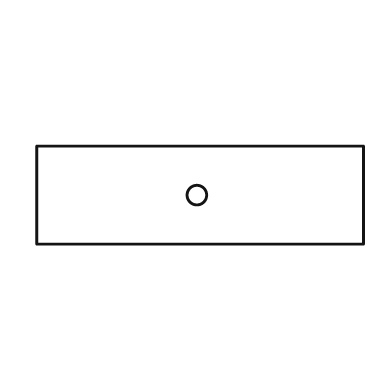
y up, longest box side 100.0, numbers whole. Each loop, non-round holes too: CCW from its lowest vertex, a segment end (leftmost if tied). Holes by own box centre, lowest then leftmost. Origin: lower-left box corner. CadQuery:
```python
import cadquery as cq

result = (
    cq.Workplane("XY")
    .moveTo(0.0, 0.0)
    .lineTo(100.0, 0.0)
    .lineTo(100.0, 30.0)
    .lineTo(0.0, 30.0)
    .close()
    .moveTo(49.0, 15.0)
    .circle(3.0)
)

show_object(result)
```